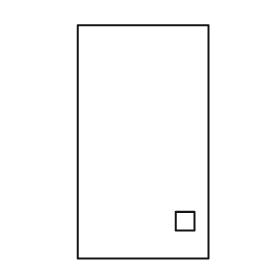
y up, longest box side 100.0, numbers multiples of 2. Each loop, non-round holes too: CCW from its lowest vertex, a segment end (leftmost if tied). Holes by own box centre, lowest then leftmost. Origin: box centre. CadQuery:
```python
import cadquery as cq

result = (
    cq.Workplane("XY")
    .moveTo(-28.0, -50.0)
    .lineTo(28.0, -50.0)
    .lineTo(28.0, 50.0)
    .lineTo(-28.0, 50.0)
    .close()
    .moveTo(14.0, -38.0)
    .lineTo(22.0, -38.0)
    .lineTo(22.0, -30.0)
    .lineTo(14.0, -30.0)
    .close()
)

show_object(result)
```